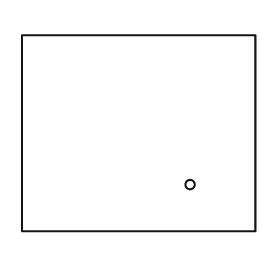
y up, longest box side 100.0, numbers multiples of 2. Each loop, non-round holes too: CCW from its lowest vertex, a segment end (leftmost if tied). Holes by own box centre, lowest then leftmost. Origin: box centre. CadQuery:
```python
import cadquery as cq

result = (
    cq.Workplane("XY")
    .moveTo(-50.0, -42.0)
    .lineTo(50.0, -42.0)
    .lineTo(50.0, 42.0)
    .lineTo(-50.0, 42.0)
    .close()
    .moveTo(22.0, -22.0)
    .circle(2.0)
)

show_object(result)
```